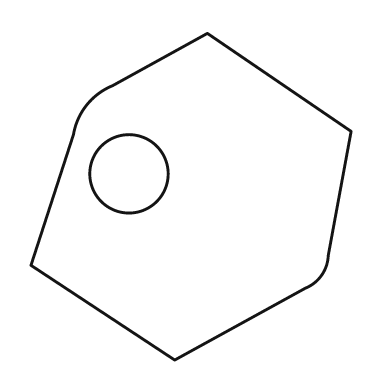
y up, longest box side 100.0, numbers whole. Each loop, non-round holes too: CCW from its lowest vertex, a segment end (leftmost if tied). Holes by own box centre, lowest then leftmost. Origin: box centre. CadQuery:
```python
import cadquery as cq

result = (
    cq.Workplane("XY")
    .moveTo(-5.0, -50.0)
    .lineTo(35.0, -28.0)
    .threePointArc((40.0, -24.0), (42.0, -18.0))
    .lineTo(49.0, 20.0)
    .lineTo(5.0, 50.0)
    .lineTo(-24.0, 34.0)
    .threePointArc((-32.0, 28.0), (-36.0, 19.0))
    .lineTo(-49.0, -21.0)
    .close()
    .moveTo(-19.0, 7.0)
    .circle(12.0)
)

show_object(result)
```